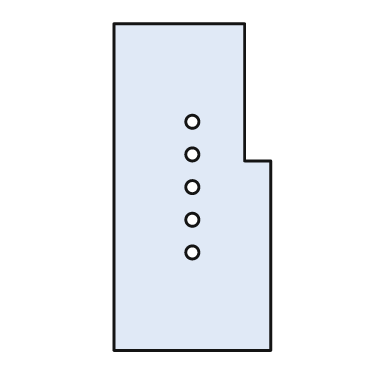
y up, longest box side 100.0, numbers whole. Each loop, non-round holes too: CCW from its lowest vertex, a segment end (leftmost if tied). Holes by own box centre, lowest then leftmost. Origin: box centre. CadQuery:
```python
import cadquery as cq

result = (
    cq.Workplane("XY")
    .moveTo(-24.0, -50.0)
    .lineTo(24.0, -50.0)
    .lineTo(24.0, 8.0)
    .lineTo(16.0, 8.0)
    .lineTo(16.0, 50.0)
    .lineTo(-24.0, 50.0)
    .close()
    .moveTo(0.0, -20.0)
    .circle(2.0)
    .moveTo(0.0, -10.0)
    .circle(2.0)
    .moveTo(0.0, 0.0)
    .circle(2.0)
    .moveTo(0.0, 10.0)
    .circle(2.0)
    .moveTo(0.0, 20.0)
    .circle(2.0)
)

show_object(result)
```